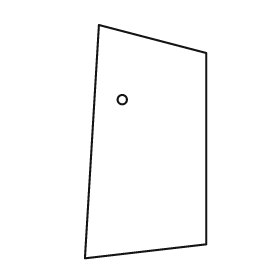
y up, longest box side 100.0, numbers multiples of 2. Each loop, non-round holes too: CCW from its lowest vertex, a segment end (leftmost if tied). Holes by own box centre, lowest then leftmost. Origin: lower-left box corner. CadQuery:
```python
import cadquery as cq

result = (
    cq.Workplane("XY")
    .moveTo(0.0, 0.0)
    .lineTo(52.0, 6.0)
    .lineTo(52.0, 88.0)
    .lineTo(6.0, 100.0)
    .close()
    .moveTo(16.0, 68.0)
    .circle(2.0)
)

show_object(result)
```